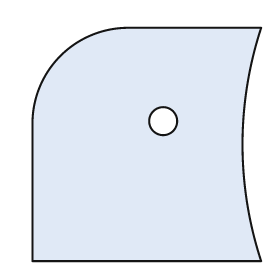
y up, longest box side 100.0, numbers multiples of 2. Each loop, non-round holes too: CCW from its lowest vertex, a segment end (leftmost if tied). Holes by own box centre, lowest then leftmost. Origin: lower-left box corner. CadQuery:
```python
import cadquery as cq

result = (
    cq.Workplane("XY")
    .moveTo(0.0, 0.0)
    .lineTo(98.0, 0.0)
    .threePointArc((90.0, 50.0), (98.0, 100.0))
    .lineTo(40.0, 100.0)
    .threePointArc((12.0, 88.0), (0.0, 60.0))
    .close()
    .moveTo(56.0, 60.0)
    .circle(6.0)
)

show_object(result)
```